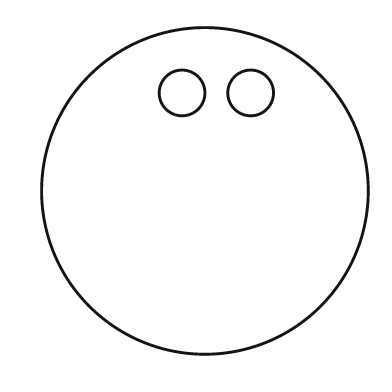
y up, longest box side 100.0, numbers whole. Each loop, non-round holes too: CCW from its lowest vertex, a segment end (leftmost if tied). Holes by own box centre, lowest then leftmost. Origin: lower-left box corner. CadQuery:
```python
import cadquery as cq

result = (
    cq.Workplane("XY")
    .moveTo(50.0, 50.0)
    .circle(50.0)
    .moveTo(43.0, 80.0)
    .circle(7.0)
    .moveTo(64.0, 80.0)
    .circle(7.0)
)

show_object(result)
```